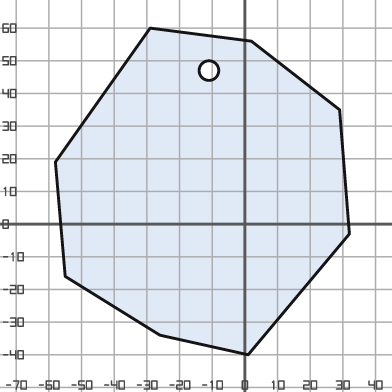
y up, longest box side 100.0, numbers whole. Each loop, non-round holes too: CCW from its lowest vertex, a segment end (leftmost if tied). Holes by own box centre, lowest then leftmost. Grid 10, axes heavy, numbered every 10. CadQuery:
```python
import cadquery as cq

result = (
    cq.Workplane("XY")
    .moveTo(1.0, -40.0)
    .lineTo(32.0, -3.0)
    .lineTo(29.0, 35.0)
    .lineTo(2.0, 56.0)
    .lineTo(-29.0, 60.0)
    .lineTo(-58.0, 19.0)
    .lineTo(-55.0, -16.0)
    .lineTo(-26.0, -34.0)
    .close()
    .moveTo(-11.0, 47.0)
    .circle(3.0)
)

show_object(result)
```